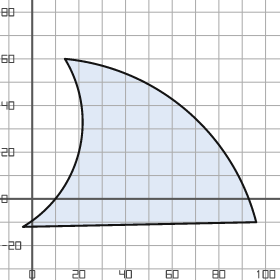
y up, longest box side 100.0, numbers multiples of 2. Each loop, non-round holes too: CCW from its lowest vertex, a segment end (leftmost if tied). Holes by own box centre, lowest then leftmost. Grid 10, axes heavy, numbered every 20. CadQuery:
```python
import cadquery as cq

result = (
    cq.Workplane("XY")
    .moveTo(-4.0, -12.0)
    .lineTo(96.0, -10.0)
    .threePointArc((66.0, 38.0), (14.0, 60.0))
    .threePointArc((20.0, 20.0), (-4.0, -12.0))
    .close()
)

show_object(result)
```